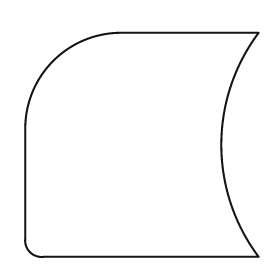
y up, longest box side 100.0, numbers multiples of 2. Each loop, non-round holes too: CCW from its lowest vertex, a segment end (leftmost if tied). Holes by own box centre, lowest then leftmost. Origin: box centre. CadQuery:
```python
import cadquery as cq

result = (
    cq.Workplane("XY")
    .moveTo(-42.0, -48.0)
    .lineTo(50.0, -48.0)
    .threePointArc((34.0, 0.0), (50.0, 48.0))
    .lineTo(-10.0, 48.0)
    .threePointArc((-38.0, 36.0), (-50.0, 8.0))
    .lineTo(-50.0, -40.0)
    .threePointArc((-48.0, -46.0), (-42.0, -48.0))
    .close()
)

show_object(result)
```